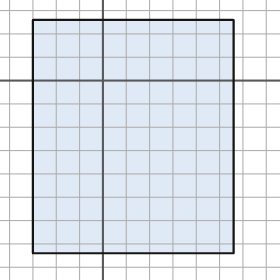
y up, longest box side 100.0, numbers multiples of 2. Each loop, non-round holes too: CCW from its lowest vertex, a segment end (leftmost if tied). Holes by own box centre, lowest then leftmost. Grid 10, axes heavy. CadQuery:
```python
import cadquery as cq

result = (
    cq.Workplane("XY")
    .moveTo(-30.0, -74.0)
    .lineTo(56.0, -74.0)
    .lineTo(56.0, 26.0)
    .lineTo(-30.0, 26.0)
    .close()
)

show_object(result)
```